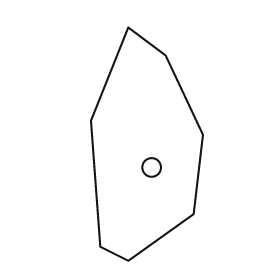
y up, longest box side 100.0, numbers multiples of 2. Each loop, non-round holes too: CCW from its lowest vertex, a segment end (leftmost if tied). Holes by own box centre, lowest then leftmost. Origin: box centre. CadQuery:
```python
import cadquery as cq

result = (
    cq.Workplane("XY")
    .moveTo(-8.0, -50.0)
    .lineTo(20.0, -30.0)
    .lineTo(24.0, 4.0)
    .lineTo(8.0, 38.0)
    .lineTo(-8.0, 50.0)
    .lineTo(-24.0, 10.0)
    .lineTo(-20.0, -44.0)
    .close()
    .moveTo(2.0, -10.0)
    .circle(4.0)
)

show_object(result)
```